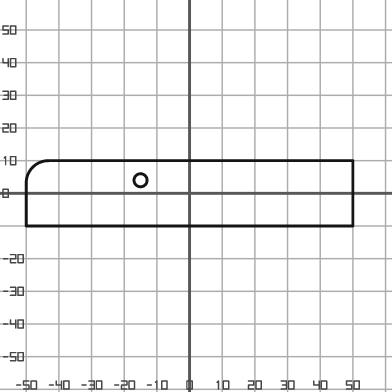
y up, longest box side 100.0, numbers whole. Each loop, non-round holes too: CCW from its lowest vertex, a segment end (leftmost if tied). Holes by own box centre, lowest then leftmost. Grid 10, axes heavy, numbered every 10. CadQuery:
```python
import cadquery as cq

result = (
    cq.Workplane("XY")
    .moveTo(-50.0, -10.0)
    .lineTo(50.0, -10.0)
    .lineTo(50.0, 10.0)
    .lineTo(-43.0, 10.0)
    .threePointArc((-48.0, 8.0), (-50.0, 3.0))
    .close()
    .moveTo(-15.0, 4.0)
    .circle(2.0)
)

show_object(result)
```